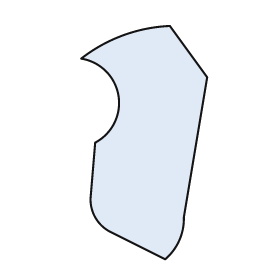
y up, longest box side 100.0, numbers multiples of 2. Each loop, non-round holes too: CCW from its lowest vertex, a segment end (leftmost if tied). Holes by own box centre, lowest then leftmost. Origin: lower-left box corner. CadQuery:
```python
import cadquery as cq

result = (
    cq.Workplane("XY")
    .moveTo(36.0, 0.0)
    .threePointArc((42.0, 8.0), (44.0, 18.0))
    .lineTo(54.0, 78.0)
    .lineTo(38.0, 100.0)
    .threePointArc((18.0, 96.0), (0.0, 86.0))
    .threePointArc((16.0, 70.0), (6.0, 50.0))
    .lineTo(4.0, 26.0)
    .threePointArc((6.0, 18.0), (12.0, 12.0))
    .close()
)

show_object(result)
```